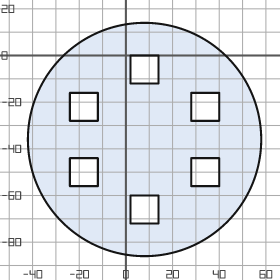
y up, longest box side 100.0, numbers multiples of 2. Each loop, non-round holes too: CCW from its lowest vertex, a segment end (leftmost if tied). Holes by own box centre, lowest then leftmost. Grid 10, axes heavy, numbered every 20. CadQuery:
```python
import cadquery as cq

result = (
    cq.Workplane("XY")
    .moveTo(8.0, -36.0)
    .circle(50.0)
    .moveTo(2.0, -72.0)
    .lineTo(14.0, -72.0)
    .lineTo(14.0, -60.0)
    .lineTo(2.0, -60.0)
    .close()
    .moveTo(-24.0, -56.0)
    .lineTo(-12.0, -56.0)
    .lineTo(-12.0, -44.0)
    .lineTo(-24.0, -44.0)
    .close()
    .moveTo(28.0, -56.0)
    .lineTo(40.0, -56.0)
    .lineTo(40.0, -44.0)
    .lineTo(28.0, -44.0)
    .close()
    .moveTo(-24.0, -28.0)
    .lineTo(-12.0, -28.0)
    .lineTo(-12.0, -16.0)
    .lineTo(-24.0, -16.0)
    .close()
    .moveTo(28.0, -28.0)
    .lineTo(40.0, -28.0)
    .lineTo(40.0, -16.0)
    .lineTo(28.0, -16.0)
    .close()
    .moveTo(2.0, -12.0)
    .lineTo(14.0, -12.0)
    .lineTo(14.0, 0.0)
    .lineTo(2.0, 0.0)
    .close()
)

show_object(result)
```